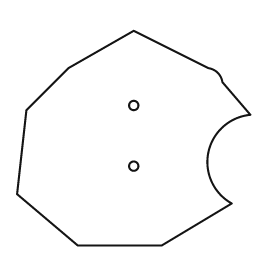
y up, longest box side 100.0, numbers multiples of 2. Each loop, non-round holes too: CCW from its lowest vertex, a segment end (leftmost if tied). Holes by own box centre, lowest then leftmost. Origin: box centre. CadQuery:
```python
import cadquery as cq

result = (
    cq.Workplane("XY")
    .moveTo(-24.0, -46.0)
    .lineTo(12.0, -46.0)
    .lineTo(42.0, -28.0)
    .threePointArc((32.0, -6.0), (50.0, 10.0))
    .lineTo(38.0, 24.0)
    .threePointArc((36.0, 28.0), (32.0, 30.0))
    .lineTo(0.0, 46.0)
    .lineTo(-28.0, 30.0)
    .lineTo(-46.0, 12.0)
    .lineTo(-50.0, -24.0)
    .close()
    .moveTo(0.0, -12.0)
    .circle(2.0)
    .moveTo(0.0, 14.0)
    .circle(2.0)
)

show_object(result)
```